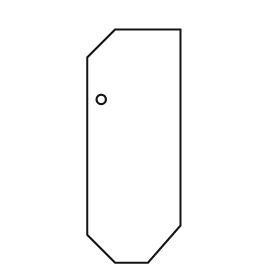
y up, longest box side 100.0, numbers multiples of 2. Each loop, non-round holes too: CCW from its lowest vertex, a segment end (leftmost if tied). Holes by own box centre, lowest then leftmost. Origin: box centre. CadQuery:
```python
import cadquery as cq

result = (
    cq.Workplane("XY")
    .moveTo(-8.0, -50.0)
    .lineTo(6.0, -50.0)
    .lineTo(20.0, -34.0)
    .lineTo(20.0, 50.0)
    .lineTo(-8.0, 50.0)
    .lineTo(-20.0, 38.0)
    .lineTo(-20.0, -38.0)
    .close()
    .moveTo(-14.0, 20.0)
    .circle(2.0)
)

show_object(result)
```